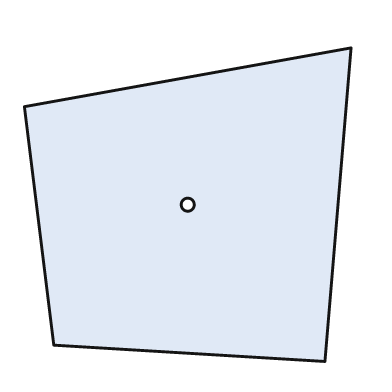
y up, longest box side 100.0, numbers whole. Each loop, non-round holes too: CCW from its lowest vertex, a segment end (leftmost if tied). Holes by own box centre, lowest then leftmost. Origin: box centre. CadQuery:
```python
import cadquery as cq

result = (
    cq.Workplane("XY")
    .moveTo(42.0, -48.0)
    .lineTo(50.0, 48.0)
    .lineTo(-50.0, 30.0)
    .lineTo(-41.0, -43.0)
    .close()
    .moveTo(0.0, 0.0)
    .circle(2.0)
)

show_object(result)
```